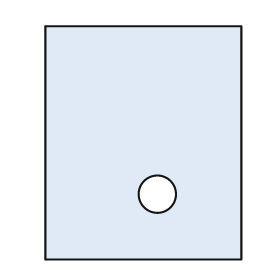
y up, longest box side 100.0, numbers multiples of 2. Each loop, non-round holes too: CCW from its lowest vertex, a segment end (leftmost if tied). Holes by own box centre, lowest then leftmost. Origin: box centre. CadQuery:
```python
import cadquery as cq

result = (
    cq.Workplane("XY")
    .moveTo(-42.0, -50.0)
    .lineTo(42.0, -50.0)
    .lineTo(42.0, 50.0)
    .lineTo(-42.0, 50.0)
    .close()
    .moveTo(6.0, -22.0)
    .circle(8.0)
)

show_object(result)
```